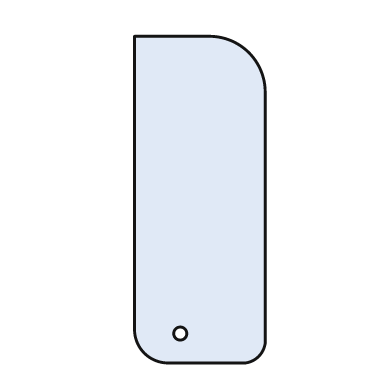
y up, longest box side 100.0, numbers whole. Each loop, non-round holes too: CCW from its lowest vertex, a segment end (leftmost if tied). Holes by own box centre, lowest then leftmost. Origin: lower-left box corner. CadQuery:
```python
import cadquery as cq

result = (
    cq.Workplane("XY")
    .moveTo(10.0, 0.0)
    .lineTo(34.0, 0.0)
    .threePointArc((38.0, 2.0), (40.0, 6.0))
    .lineTo(40.0, 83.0)
    .threePointArc((35.0, 95.0), (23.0, 100.0))
    .lineTo(0.0, 100.0)
    .lineTo(0.0, 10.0)
    .threePointArc((3.0, 3.0), (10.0, 0.0))
    .close()
    .moveTo(14.0, 9.0)
    .circle(2.0)
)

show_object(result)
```